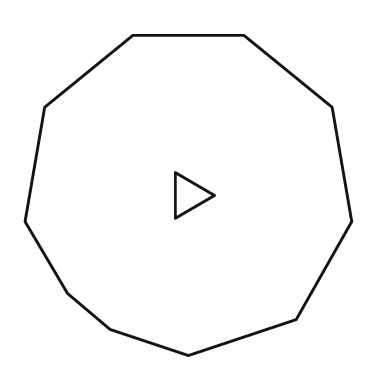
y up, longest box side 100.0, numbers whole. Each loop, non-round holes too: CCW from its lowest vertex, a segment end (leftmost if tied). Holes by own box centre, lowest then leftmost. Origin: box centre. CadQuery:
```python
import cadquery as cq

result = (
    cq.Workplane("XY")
    .moveTo(0.0, -49.0)
    .lineTo(33.0, -38.0)
    .lineTo(50.0, -8.0)
    .lineTo(44.0, 27.0)
    .lineTo(17.0, 49.0)
    .lineTo(-17.0, 49.0)
    .lineTo(-44.0, 27.0)
    .lineTo(-50.0, -8.0)
    .lineTo(-37.0, -30.0)
    .lineTo(-24.0, -41.0)
    .close()
    .moveTo(-4.0, -7.0)
    .lineTo(8.0, 0.0)
    .lineTo(-4.0, 7.0)
    .close()
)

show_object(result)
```